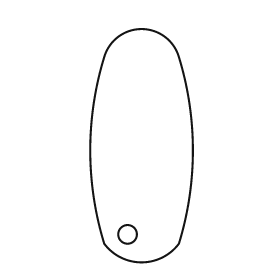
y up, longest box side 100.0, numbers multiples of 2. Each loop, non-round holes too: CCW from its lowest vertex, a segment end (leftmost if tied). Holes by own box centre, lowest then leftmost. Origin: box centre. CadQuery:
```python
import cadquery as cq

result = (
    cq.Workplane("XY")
    .moveTo(-16.0, -42.0)
    .threePointArc((0.0, -50.0), (16.0, -42.0))
    .threePointArc((22.0, -2.0), (16.0, 38.0))
    .threePointArc((0.0, 50.0), (-16.0, 38.0))
    .threePointArc((-22.0, -2.0), (-16.0, -42.0))
    .close()
    .moveTo(-6.0, -38.0)
    .circle(4.0)
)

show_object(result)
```